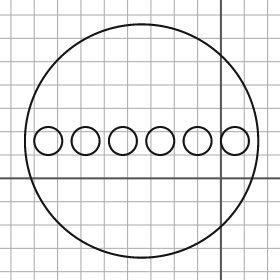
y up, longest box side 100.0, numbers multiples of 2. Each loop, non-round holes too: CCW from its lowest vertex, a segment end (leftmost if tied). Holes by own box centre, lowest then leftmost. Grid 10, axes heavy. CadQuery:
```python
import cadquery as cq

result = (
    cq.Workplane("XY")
    .moveTo(-34.0, 16.0)
    .circle(50.0)
    .moveTo(-74.0, 16.0)
    .circle(6.0)
    .moveTo(-58.0, 16.0)
    .circle(6.0)
    .moveTo(-42.0, 16.0)
    .circle(6.0)
    .moveTo(-26.0, 16.0)
    .circle(6.0)
    .moveTo(-10.0, 16.0)
    .circle(6.0)
    .moveTo(6.0, 16.0)
    .circle(6.0)
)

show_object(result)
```